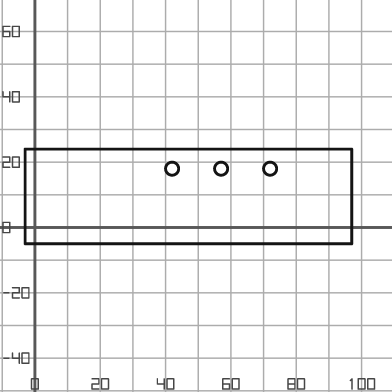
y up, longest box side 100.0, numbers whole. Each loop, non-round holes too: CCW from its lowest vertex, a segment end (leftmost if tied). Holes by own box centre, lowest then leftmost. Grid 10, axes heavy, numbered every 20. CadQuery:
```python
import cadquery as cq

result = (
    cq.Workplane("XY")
    .moveTo(-3.0, -5.0)
    .lineTo(97.0, -5.0)
    .lineTo(97.0, 24.0)
    .lineTo(-3.0, 24.0)
    .close()
    .moveTo(42.0, 18.0)
    .circle(2.0)
    .moveTo(57.0, 18.0)
    .circle(2.0)
    .moveTo(72.0, 18.0)
    .circle(2.0)
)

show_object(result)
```